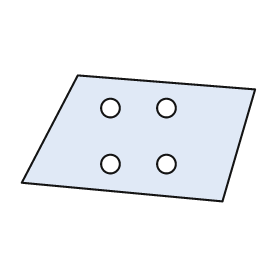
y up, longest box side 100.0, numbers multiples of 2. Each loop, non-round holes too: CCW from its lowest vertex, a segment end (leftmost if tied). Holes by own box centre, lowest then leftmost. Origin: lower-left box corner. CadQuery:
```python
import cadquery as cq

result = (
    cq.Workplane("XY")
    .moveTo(86.0, 0.0)
    .lineTo(100.0, 48.0)
    .lineTo(24.0, 54.0)
    .lineTo(0.0, 8.0)
    .close()
    .moveTo(38.0, 16.0)
    .circle(4.0)
    .moveTo(62.0, 16.0)
    .circle(4.0)
    .moveTo(38.0, 40.0)
    .circle(4.0)
    .moveTo(62.0, 40.0)
    .circle(4.0)
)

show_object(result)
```